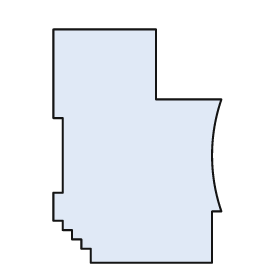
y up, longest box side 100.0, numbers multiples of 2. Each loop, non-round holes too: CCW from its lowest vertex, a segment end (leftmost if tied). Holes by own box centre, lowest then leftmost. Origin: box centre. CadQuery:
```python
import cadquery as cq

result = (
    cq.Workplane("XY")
    .moveTo(-20.0, -50.0)
    .lineTo(32.0, -50.0)
    .lineTo(32.0, -28.0)
    .lineTo(36.0, -28.0)
    .threePointArc((32.0, -4.0), (36.0, 20.0))
    .lineTo(8.0, 20.0)
    .lineTo(8.0, 50.0)
    .lineTo(-36.0, 50.0)
    .lineTo(-36.0, 12.0)
    .lineTo(-32.0, 12.0)
    .lineTo(-32.0, -20.0)
    .lineTo(-36.0, -20.0)
    .lineTo(-36.0, -32.0)
    .lineTo(-32.0, -32.0)
    .lineTo(-32.0, -36.0)
    .lineTo(-28.0, -36.0)
    .lineTo(-28.0, -40.0)
    .lineTo(-24.0, -40.0)
    .lineTo(-24.0, -44.0)
    .lineTo(-20.0, -44.0)
    .close()
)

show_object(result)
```